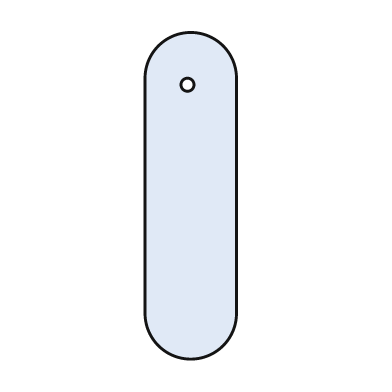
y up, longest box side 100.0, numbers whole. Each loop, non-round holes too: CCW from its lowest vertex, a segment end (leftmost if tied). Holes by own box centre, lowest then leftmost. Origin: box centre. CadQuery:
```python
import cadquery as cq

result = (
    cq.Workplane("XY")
    .moveTo(-14.0, -36.0)
    .threePointArc((0.0, -50.0), (14.0, -36.0))
    .lineTo(14.0, 36.0)
    .threePointArc((0.0, 50.0), (-14.0, 36.0))
    .close()
    .moveTo(-1.0, 34.0)
    .circle(2.0)
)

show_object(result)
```